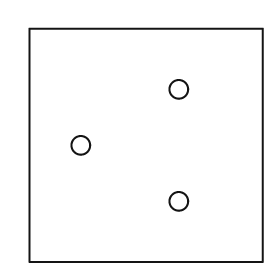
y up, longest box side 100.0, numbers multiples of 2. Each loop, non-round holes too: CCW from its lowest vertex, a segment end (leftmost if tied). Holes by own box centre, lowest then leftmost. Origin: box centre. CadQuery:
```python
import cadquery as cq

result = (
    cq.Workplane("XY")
    .moveTo(-50.0, -50.0)
    .lineTo(50.0, -50.0)
    .lineTo(50.0, 50.0)
    .lineTo(-50.0, 50.0)
    .close()
    .moveTo(14.0, -24.0)
    .circle(4.0)
    .moveTo(-28.0, 0.0)
    .circle(4.0)
    .moveTo(14.0, 24.0)
    .circle(4.0)
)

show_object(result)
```